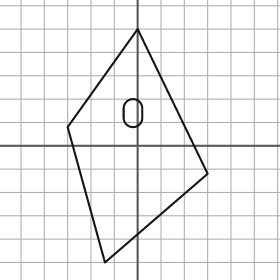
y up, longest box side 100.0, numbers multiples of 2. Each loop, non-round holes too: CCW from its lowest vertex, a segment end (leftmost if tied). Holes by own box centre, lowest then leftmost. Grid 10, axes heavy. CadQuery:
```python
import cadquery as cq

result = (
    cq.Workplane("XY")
    .moveTo(-14.0, -50.0)
    .lineTo(30.0, -12.0)
    .lineTo(0.0, 50.0)
    .lineTo(-30.0, 8.0)
    .close()
    .moveTo(-6.0, 12.0)
    .threePointArc((-2.0, 8.0), (2.0, 12.0))
    .lineTo(2.0, 16.0)
    .threePointArc((-2.0, 20.0), (-6.0, 16.0))
    .close()
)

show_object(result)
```